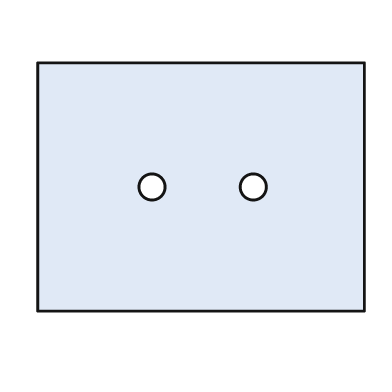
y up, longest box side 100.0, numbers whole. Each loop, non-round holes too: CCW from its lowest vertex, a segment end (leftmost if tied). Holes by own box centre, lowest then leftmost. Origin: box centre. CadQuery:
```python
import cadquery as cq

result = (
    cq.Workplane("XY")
    .moveTo(-50.0, -38.0)
    .lineTo(50.0, -38.0)
    .lineTo(50.0, 38.0)
    .lineTo(-50.0, 38.0)
    .close()
    .moveTo(-15.0, 0.0)
    .circle(4.0)
    .moveTo(16.0, 0.0)
    .circle(4.0)
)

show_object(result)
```